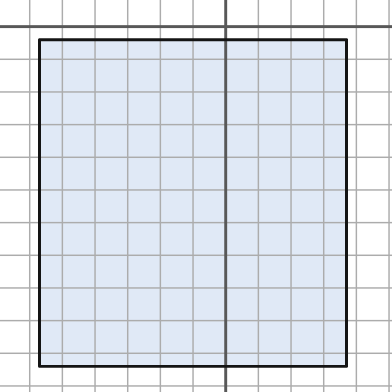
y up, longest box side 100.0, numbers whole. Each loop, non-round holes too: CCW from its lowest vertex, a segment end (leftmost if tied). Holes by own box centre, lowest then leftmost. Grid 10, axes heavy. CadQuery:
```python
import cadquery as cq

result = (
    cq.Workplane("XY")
    .moveTo(-57.0, -104.0)
    .lineTo(37.0, -104.0)
    .lineTo(37.0, -4.0)
    .lineTo(-57.0, -4.0)
    .close()
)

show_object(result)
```